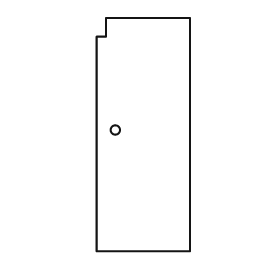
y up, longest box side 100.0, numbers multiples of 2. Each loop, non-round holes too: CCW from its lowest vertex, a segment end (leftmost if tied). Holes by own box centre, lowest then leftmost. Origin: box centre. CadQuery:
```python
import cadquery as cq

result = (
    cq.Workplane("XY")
    .moveTo(-20.0, -50.0)
    .lineTo(20.0, -50.0)
    .lineTo(20.0, 50.0)
    .lineTo(-16.0, 50.0)
    .lineTo(-16.0, 42.0)
    .lineTo(-20.0, 42.0)
    .close()
    .moveTo(-12.0, 2.0)
    .circle(2.0)
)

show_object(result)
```